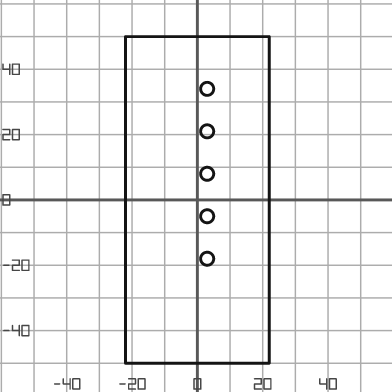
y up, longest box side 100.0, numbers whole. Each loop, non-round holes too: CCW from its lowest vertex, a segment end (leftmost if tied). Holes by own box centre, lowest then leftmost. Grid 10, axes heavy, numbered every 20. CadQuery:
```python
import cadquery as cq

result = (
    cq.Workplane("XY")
    .moveTo(-22.0, -50.0)
    .lineTo(22.0, -50.0)
    .lineTo(22.0, 50.0)
    .lineTo(-22.0, 50.0)
    .close()
    .moveTo(3.0, -18.0)
    .circle(2.0)
    .moveTo(3.0, -5.0)
    .circle(2.0)
    .moveTo(3.0, 8.0)
    .circle(2.0)
    .moveTo(3.0, 21.0)
    .circle(2.0)
    .moveTo(3.0, 34.0)
    .circle(2.0)
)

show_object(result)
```